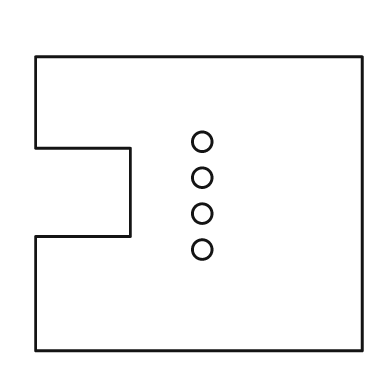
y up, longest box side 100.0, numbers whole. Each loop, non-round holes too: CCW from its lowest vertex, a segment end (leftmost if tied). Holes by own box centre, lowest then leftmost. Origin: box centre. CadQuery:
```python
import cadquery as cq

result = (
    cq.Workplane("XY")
    .moveTo(-50.0, -45.0)
    .lineTo(50.0, -45.0)
    .lineTo(50.0, 45.0)
    .lineTo(-50.0, 45.0)
    .lineTo(-50.0, 17.0)
    .lineTo(-21.0, 17.0)
    .lineTo(-21.0, -10.0)
    .lineTo(-50.0, -10.0)
    .close()
    .moveTo(1.0, -14.0)
    .circle(3.0)
    .moveTo(1.0, -3.0)
    .circle(3.0)
    .moveTo(1.0, 8.0)
    .circle(3.0)
    .moveTo(1.0, 19.0)
    .circle(3.0)
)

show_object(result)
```